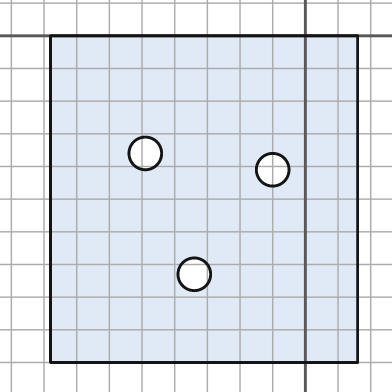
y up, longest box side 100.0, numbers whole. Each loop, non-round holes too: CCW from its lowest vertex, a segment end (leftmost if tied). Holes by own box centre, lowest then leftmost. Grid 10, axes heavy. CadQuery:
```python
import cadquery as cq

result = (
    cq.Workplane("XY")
    .moveTo(-78.0, -100.0)
    .lineTo(16.0, -100.0)
    .lineTo(16.0, 0.0)
    .lineTo(-78.0, 0.0)
    .close()
    .moveTo(-34.0, -73.0)
    .circle(5.0)
    .moveTo(-10.0, -41.0)
    .circle(5.0)
    .moveTo(-49.0, -36.0)
    .circle(5.0)
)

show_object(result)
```